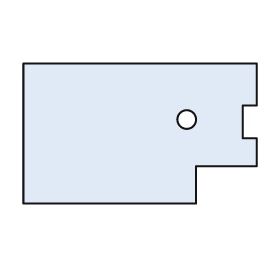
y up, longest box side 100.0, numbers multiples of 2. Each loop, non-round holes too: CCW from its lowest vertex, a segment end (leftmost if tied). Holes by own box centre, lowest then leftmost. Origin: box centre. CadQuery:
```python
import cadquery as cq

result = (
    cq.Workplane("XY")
    .moveTo(-50.0, -30.0)
    .lineTo(24.0, -30.0)
    .lineTo(24.0, -14.0)
    .lineTo(50.0, -14.0)
    .lineTo(50.0, -2.0)
    .lineTo(44.0, -2.0)
    .lineTo(44.0, 12.0)
    .lineTo(50.0, 12.0)
    .lineTo(50.0, 30.0)
    .lineTo(-50.0, 30.0)
    .close()
    .moveTo(20.0, 6.0)
    .circle(4.0)
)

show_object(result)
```